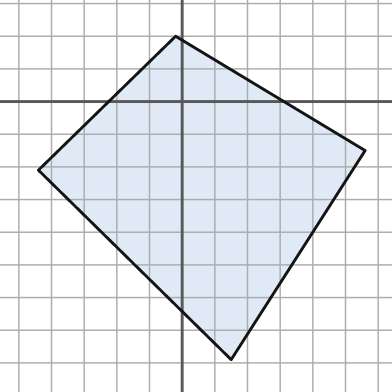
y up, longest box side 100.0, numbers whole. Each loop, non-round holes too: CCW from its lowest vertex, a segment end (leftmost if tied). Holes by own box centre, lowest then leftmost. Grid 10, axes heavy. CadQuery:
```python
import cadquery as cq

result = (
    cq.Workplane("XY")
    .moveTo(15.0, -79.0)
    .lineTo(56.0, -15.0)
    .lineTo(-2.0, 20.0)
    .lineTo(-44.0, -21.0)
    .close()
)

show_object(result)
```